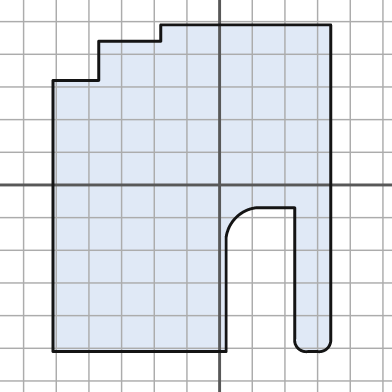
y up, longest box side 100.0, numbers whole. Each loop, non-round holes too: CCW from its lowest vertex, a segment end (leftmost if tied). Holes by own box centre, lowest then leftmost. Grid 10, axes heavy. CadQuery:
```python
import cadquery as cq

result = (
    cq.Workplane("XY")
    .moveTo(-51.0, -51.0)
    .lineTo(2.0, -51.0)
    .lineTo(2.0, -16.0)
    .threePointArc((5.0, -10.0), (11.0, -7.0))
    .lineTo(23.0, -7.0)
    .lineTo(23.0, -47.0)
    .threePointArc((24.0, -50.0), (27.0, -51.0))
    .lineTo(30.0, -51.0)
    .threePointArc((33.0, -50.0), (34.0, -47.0))
    .lineTo(34.0, 49.0)
    .lineTo(-18.0, 49.0)
    .lineTo(-18.0, 44.0)
    .lineTo(-37.0, 44.0)
    .lineTo(-37.0, 32.0)
    .lineTo(-51.0, 32.0)
    .close()
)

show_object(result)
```